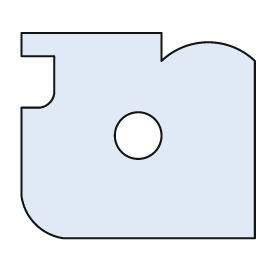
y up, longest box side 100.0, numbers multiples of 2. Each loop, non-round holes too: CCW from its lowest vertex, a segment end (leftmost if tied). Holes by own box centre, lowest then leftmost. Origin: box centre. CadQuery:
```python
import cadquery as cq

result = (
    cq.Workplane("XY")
    .moveTo(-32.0, -44.0)
    .lineTo(50.0, -44.0)
    .lineTo(50.0, 32.0)
    .threePointArc((30.0, 40.0), (10.0, 32.0))
    .lineTo(10.0, 44.0)
    .lineTo(-50.0, 44.0)
    .lineTo(-50.0, 34.0)
    .lineTo(-36.0, 34.0)
    .lineTo(-36.0, 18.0)
    .threePointArc((-38.0, 14.0), (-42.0, 12.0))
    .lineTo(-50.0, 12.0)
    .lineTo(-50.0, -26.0)
    .threePointArc((-44.0, -38.0), (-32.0, -44.0))
    .close()
    .moveTo(0.0, 0.0)
    .circle(10.0)
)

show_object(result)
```